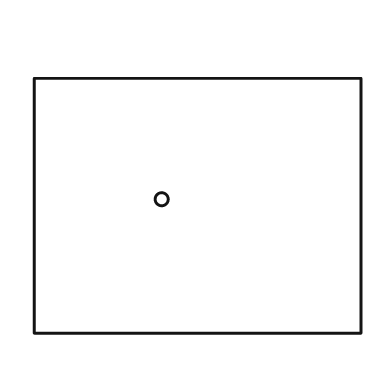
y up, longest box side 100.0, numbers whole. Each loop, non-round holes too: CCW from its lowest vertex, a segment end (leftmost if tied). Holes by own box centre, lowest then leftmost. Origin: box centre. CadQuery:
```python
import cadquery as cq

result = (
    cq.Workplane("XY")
    .moveTo(-50.0, -39.0)
    .lineTo(50.0, -39.0)
    .lineTo(50.0, 39.0)
    .lineTo(-50.0, 39.0)
    .close()
    .moveTo(-11.0, 2.0)
    .circle(2.0)
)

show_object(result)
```